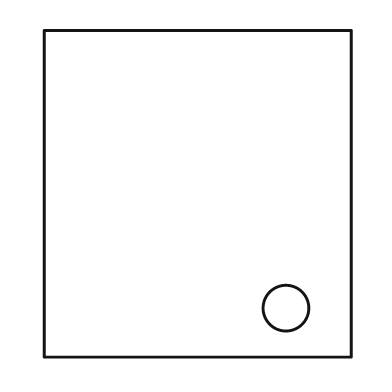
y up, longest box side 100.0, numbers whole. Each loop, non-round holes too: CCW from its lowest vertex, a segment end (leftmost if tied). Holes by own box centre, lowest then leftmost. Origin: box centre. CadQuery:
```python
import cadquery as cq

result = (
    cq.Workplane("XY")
    .moveTo(-47.0, -50.0)
    .lineTo(47.0, -50.0)
    .lineTo(47.0, 50.0)
    .lineTo(-47.0, 50.0)
    .close()
    .moveTo(27.0, -35.0)
    .circle(7.0)
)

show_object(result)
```